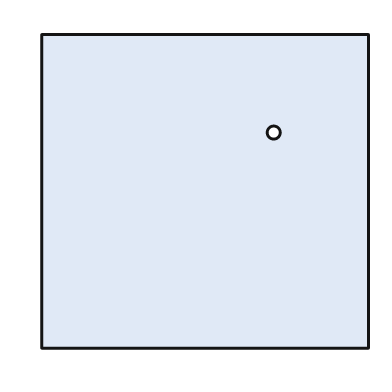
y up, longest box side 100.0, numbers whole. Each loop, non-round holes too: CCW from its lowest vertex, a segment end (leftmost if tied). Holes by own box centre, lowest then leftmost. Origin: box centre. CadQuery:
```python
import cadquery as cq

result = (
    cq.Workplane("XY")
    .moveTo(-50.0, -48.0)
    .lineTo(50.0, -48.0)
    .lineTo(50.0, 48.0)
    .lineTo(-50.0, 48.0)
    .close()
    .moveTo(21.0, 18.0)
    .circle(2.0)
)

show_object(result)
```